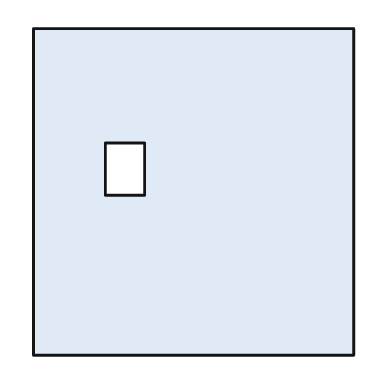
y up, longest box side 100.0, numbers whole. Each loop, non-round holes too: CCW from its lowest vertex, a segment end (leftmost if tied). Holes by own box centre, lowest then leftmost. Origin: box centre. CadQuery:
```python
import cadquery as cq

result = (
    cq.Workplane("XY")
    .moveTo(-49.0, -50.0)
    .lineTo(49.0, -50.0)
    .lineTo(49.0, 50.0)
    .lineTo(-49.0, 50.0)
    .close()
    .moveTo(-27.0, -1.0)
    .lineTo(-15.0, -1.0)
    .lineTo(-15.0, 15.0)
    .lineTo(-27.0, 15.0)
    .close()
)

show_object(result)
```